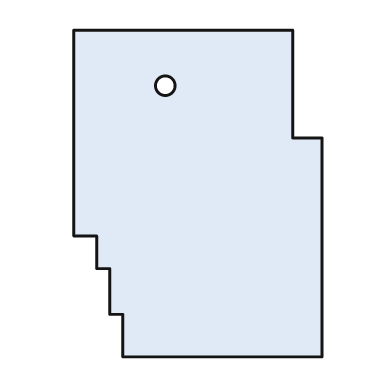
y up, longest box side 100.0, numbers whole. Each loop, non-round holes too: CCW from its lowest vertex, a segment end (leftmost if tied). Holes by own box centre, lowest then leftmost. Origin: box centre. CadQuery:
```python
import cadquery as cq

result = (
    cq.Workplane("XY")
    .moveTo(-23.0, -50.0)
    .lineTo(38.0, -50.0)
    .lineTo(38.0, 17.0)
    .lineTo(29.0, 17.0)
    .lineTo(29.0, 50.0)
    .lineTo(-38.0, 50.0)
    .lineTo(-38.0, -13.0)
    .lineTo(-31.0, -13.0)
    .lineTo(-31.0, -23.0)
    .lineTo(-27.0, -23.0)
    .lineTo(-27.0, -37.0)
    .lineTo(-23.0, -37.0)
    .close()
    .moveTo(-10.0, 33.0)
    .circle(3.0)
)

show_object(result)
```